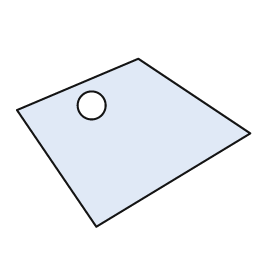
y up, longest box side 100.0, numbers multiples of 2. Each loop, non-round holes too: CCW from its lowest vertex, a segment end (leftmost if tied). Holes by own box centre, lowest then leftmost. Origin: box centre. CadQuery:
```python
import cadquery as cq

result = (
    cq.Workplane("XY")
    .moveTo(-16.0, -36.0)
    .lineTo(50.0, 4.0)
    .lineTo(2.0, 36.0)
    .lineTo(-50.0, 14.0)
    .close()
    .moveTo(-18.0, 16.0)
    .circle(6.0)
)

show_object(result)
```